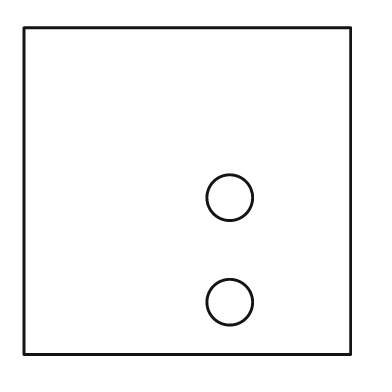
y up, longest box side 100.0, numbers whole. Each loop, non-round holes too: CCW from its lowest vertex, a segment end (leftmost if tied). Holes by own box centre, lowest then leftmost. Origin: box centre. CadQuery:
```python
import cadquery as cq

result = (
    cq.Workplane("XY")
    .moveTo(-50.0, -50.0)
    .lineTo(50.0, -50.0)
    .lineTo(50.0, 50.0)
    .lineTo(-50.0, 50.0)
    .close()
    .moveTo(13.0, -34.0)
    .circle(7.0)
    .moveTo(13.0, -2.0)
    .circle(7.0)
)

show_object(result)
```